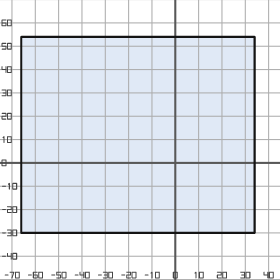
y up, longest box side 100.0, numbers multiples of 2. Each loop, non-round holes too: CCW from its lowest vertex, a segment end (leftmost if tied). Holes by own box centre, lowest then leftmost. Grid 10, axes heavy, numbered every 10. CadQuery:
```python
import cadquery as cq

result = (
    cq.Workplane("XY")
    .moveTo(-66.0, -30.0)
    .lineTo(34.0, -30.0)
    .lineTo(34.0, 54.0)
    .lineTo(-66.0, 54.0)
    .close()
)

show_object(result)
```